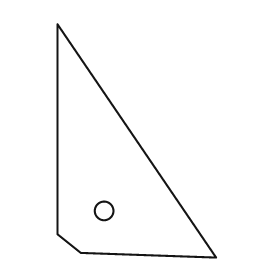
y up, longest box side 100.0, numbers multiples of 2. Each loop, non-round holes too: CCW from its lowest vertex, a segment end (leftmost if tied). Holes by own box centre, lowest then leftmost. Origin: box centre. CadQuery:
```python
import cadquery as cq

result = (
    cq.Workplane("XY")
    .moveTo(34.0, -50.0)
    .lineTo(-34.0, 50.0)
    .lineTo(-34.0, -40.0)
    .lineTo(-24.0, -48.0)
    .close()
    .moveTo(-14.0, -30.0)
    .circle(4.0)
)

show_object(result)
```